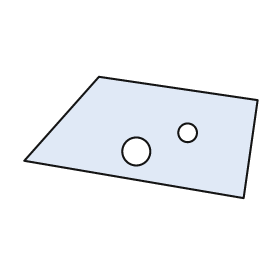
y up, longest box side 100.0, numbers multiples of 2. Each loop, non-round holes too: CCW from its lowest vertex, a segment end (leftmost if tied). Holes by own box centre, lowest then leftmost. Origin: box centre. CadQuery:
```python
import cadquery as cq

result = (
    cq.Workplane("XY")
    .moveTo(44.0, -26.0)
    .lineTo(50.0, 16.0)
    .lineTo(-18.0, 26.0)
    .lineTo(-50.0, -10.0)
    .close()
    .moveTo(-2.0, -6.0)
    .circle(6.0)
    .moveTo(20.0, 2.0)
    .circle(4.0)
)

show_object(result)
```